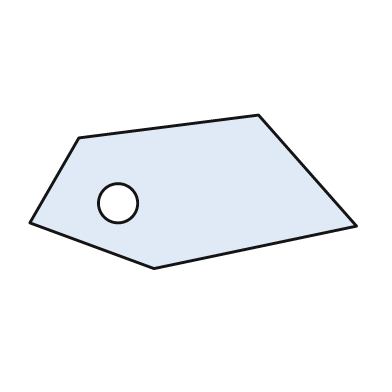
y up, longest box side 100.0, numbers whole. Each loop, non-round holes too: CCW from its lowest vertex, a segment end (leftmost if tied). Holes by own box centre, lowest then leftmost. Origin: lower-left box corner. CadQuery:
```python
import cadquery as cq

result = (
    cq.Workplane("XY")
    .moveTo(38.0, 0.0)
    .lineTo(100.0, 13.0)
    .lineTo(70.0, 47.0)
    .lineTo(15.0, 40.0)
    .lineTo(0.0, 14.0)
    .close()
    .moveTo(27.0, 20.0)
    .circle(6.0)
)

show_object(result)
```